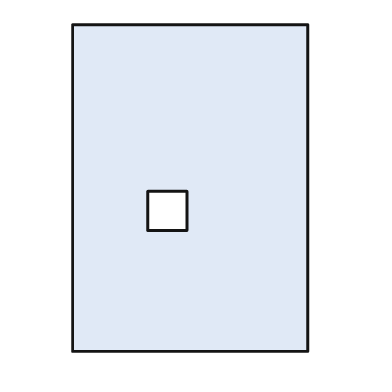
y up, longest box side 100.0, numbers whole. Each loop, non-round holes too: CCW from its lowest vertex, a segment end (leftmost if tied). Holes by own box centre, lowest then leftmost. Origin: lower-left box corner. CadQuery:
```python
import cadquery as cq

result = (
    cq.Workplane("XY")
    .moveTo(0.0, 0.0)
    .lineTo(72.0, 0.0)
    .lineTo(72.0, 100.0)
    .lineTo(0.0, 100.0)
    .close()
    .moveTo(23.0, 37.0)
    .lineTo(35.0, 37.0)
    .lineTo(35.0, 49.0)
    .lineTo(23.0, 49.0)
    .close()
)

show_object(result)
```